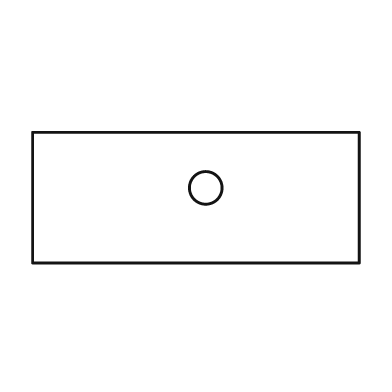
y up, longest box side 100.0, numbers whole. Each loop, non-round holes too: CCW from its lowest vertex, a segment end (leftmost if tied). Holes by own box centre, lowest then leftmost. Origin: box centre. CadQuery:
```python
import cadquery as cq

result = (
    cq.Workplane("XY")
    .moveTo(-50.0, -20.0)
    .lineTo(50.0, -20.0)
    .lineTo(50.0, 20.0)
    .lineTo(-50.0, 20.0)
    .close()
    .moveTo(3.0, 3.0)
    .circle(5.0)
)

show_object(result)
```